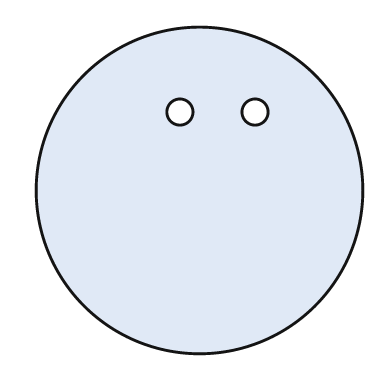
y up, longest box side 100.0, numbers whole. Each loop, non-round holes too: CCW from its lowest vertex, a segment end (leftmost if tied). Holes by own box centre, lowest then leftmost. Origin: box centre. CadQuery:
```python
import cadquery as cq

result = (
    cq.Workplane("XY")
    .moveTo(0.0, 0.0)
    .circle(50.0)
    .moveTo(-6.0, 24.0)
    .circle(4.0)
    .moveTo(17.0, 24.0)
    .circle(4.0)
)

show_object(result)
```